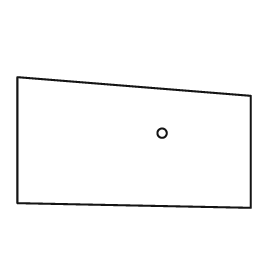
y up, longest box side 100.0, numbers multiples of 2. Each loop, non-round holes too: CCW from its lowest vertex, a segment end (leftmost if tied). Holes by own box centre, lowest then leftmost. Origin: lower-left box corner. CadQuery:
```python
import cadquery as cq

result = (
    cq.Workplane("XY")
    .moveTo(100.0, 0.0)
    .lineTo(100.0, 48.0)
    .lineTo(0.0, 56.0)
    .lineTo(0.0, 2.0)
    .close()
    .moveTo(62.0, 32.0)
    .circle(2.0)
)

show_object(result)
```